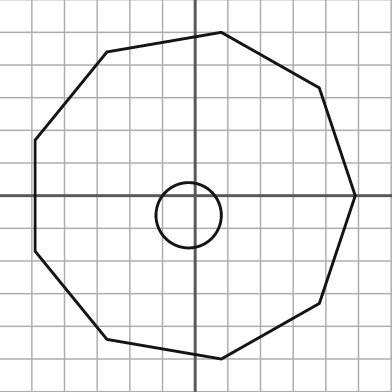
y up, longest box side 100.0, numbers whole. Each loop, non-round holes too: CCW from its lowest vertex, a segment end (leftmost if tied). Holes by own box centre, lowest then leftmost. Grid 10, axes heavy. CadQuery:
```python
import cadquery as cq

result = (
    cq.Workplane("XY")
    .moveTo(8.0, -50.0)
    .lineTo(38.0, -33.0)
    .lineTo(49.0, 0.0)
    .lineTo(38.0, 33.0)
    .lineTo(8.0, 50.0)
    .lineTo(-27.0, 44.0)
    .lineTo(-49.0, 17.0)
    .lineTo(-49.0, -17.0)
    .lineTo(-27.0, -44.0)
    .close()
    .moveTo(-2.0, -6.0)
    .circle(10.0)
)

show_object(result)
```